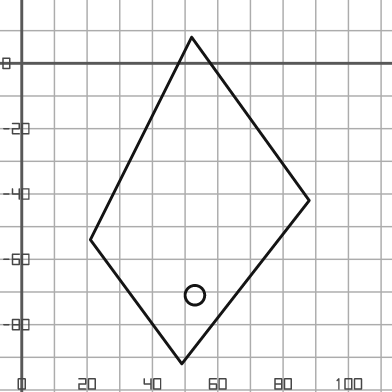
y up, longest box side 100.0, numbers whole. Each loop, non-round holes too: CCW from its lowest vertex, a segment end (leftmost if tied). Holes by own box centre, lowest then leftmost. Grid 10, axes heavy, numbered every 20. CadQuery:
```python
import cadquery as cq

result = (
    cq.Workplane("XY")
    .moveTo(49.0, -92.0)
    .lineTo(88.0, -42.0)
    .lineTo(52.0, 8.0)
    .lineTo(21.0, -54.0)
    .close()
    .moveTo(53.0, -71.0)
    .circle(3.0)
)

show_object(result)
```